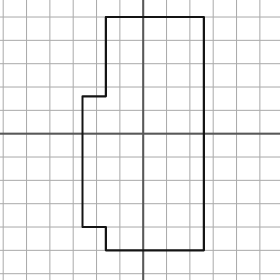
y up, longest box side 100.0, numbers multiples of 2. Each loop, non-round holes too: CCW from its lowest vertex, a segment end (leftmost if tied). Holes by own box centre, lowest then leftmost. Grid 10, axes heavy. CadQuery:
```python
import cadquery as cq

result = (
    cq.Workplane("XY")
    .moveTo(-16.0, -50.0)
    .lineTo(26.0, -50.0)
    .lineTo(26.0, 50.0)
    .lineTo(-16.0, 50.0)
    .lineTo(-16.0, 16.0)
    .lineTo(-26.0, 16.0)
    .lineTo(-26.0, -40.0)
    .lineTo(-16.0, -40.0)
    .close()
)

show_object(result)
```